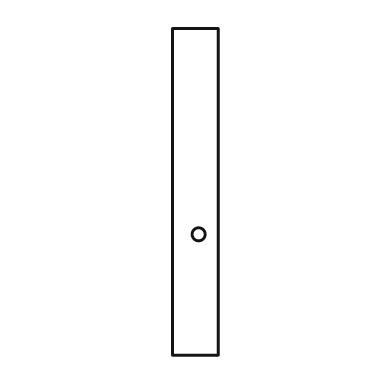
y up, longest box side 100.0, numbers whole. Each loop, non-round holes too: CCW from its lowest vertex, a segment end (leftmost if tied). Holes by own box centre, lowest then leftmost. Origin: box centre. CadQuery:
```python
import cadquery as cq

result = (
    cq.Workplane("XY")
    .moveTo(-7.0, -50.0)
    .lineTo(7.0, -50.0)
    .lineTo(7.0, 50.0)
    .lineTo(-7.0, 50.0)
    .close()
    .moveTo(1.0, -13.0)
    .circle(2.0)
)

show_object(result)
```